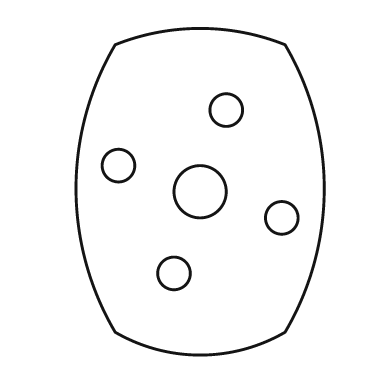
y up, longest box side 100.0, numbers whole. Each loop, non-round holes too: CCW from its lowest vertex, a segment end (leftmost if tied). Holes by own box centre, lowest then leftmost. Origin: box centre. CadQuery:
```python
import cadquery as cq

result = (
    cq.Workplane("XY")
    .moveTo(-26.0, -43.0)
    .threePointArc((0.0, -50.0), (26.0, -43.0))
    .threePointArc((38.0, 1.0), (26.0, 45.0))
    .threePointArc((0.0, 50.0), (-26.0, 45.0))
    .threePointArc((-38.0, 1.0), (-26.0, -43.0))
    .close()
    .moveTo(-8.0, -25.0)
    .circle(5.0)
    .moveTo(25.0, -8.0)
    .circle(5.0)
    .moveTo(0.0, 0.0)
    .circle(8.0)
    .moveTo(-25.0, 8.0)
    .circle(5.0)
    .moveTo(8.0, 25.0)
    .circle(5.0)
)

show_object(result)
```